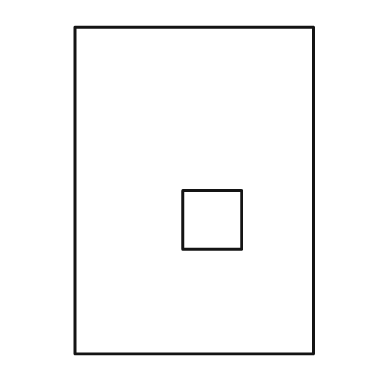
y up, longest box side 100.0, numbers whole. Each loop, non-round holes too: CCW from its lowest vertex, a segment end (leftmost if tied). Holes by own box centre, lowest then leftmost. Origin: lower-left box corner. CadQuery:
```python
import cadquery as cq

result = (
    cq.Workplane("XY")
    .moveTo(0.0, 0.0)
    .lineTo(73.0, 0.0)
    .lineTo(73.0, 100.0)
    .lineTo(0.0, 100.0)
    .close()
    .moveTo(33.0, 32.0)
    .lineTo(51.0, 32.0)
    .lineTo(51.0, 50.0)
    .lineTo(33.0, 50.0)
    .close()
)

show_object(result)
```